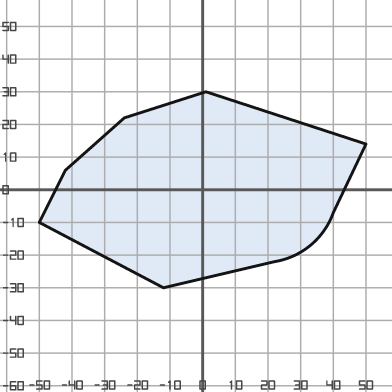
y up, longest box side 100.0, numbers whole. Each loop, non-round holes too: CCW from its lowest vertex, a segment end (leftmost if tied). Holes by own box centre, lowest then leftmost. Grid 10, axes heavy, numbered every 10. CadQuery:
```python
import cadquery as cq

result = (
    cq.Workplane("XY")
    .moveTo(-12.0, -30.0)
    .lineTo(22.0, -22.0)
    .threePointArc((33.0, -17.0), (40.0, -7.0))
    .lineTo(50.0, 14.0)
    .lineTo(1.0, 30.0)
    .lineTo(-24.0, 22.0)
    .lineTo(-42.0, 6.0)
    .lineTo(-50.0, -10.0)
    .close()
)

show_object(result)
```